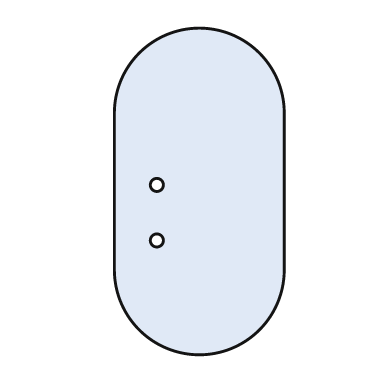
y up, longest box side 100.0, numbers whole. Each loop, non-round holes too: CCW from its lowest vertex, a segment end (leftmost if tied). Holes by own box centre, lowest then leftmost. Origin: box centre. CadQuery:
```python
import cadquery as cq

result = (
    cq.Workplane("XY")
    .moveTo(-26.0, -24.0)
    .threePointArc((0.0, -50.0), (26.0, -24.0))
    .lineTo(26.0, 24.0)
    .threePointArc((0.0, 50.0), (-26.0, 24.0))
    .close()
    .moveTo(-13.0, -15.0)
    .circle(2.0)
    .moveTo(-13.0, 2.0)
    .circle(2.0)
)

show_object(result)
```